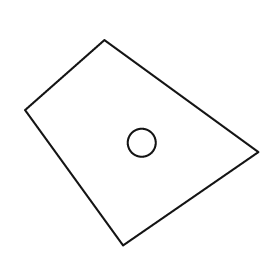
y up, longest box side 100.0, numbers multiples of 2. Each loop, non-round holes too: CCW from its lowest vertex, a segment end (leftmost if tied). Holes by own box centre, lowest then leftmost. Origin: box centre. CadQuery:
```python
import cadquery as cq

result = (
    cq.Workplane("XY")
    .moveTo(-8.0, -44.0)
    .lineTo(50.0, -4.0)
    .lineTo(-16.0, 44.0)
    .lineTo(-50.0, 14.0)
    .close()
    .moveTo(0.0, 0.0)
    .circle(6.0)
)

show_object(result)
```